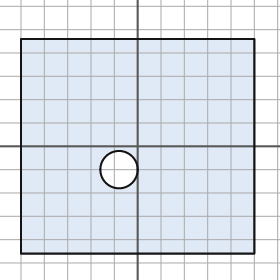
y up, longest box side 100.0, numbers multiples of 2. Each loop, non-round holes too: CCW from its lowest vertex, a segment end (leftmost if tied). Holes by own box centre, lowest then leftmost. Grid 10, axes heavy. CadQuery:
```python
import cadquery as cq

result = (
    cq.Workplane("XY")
    .moveTo(-50.0, -46.0)
    .lineTo(50.0, -46.0)
    .lineTo(50.0, 46.0)
    .lineTo(-50.0, 46.0)
    .close()
    .moveTo(-8.0, -10.0)
    .circle(8.0)
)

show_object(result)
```